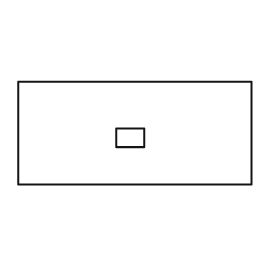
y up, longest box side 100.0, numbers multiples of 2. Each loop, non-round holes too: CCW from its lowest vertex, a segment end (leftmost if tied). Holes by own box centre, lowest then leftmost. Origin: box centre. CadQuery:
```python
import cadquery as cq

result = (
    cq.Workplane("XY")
    .moveTo(-50.0, -22.0)
    .lineTo(50.0, -22.0)
    .lineTo(50.0, 22.0)
    .lineTo(-50.0, 22.0)
    .close()
    .moveTo(-8.0, -6.0)
    .lineTo(4.0, -6.0)
    .lineTo(4.0, 2.0)
    .lineTo(-8.0, 2.0)
    .close()
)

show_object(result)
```